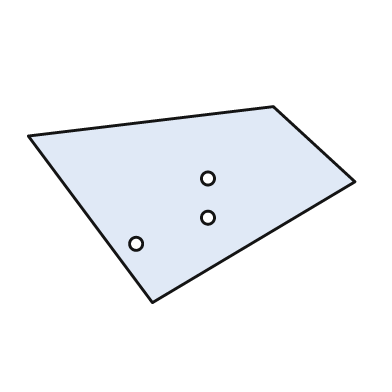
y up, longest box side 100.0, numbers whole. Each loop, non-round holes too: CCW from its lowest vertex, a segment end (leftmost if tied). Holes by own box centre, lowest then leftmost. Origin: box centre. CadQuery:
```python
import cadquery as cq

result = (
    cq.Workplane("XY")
    .moveTo(-12.0, -30.0)
    .lineTo(50.0, 7.0)
    .lineTo(25.0, 30.0)
    .lineTo(-50.0, 21.0)
    .close()
    .moveTo(-17.0, -12.0)
    .circle(2.0)
    .moveTo(5.0, -4.0)
    .circle(2.0)
    .moveTo(5.0, 8.0)
    .circle(2.0)
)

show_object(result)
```